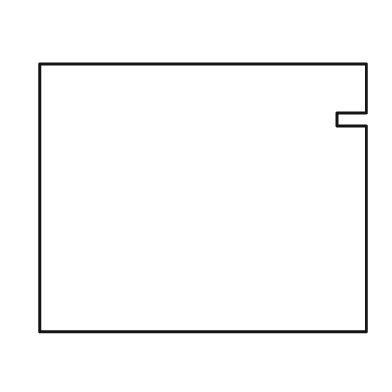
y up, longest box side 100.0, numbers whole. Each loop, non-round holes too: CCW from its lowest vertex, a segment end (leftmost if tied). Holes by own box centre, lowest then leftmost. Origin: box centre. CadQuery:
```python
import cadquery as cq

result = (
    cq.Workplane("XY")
    .moveTo(-50.0, -41.0)
    .lineTo(50.0, -41.0)
    .lineTo(50.0, 22.0)
    .lineTo(41.0, 22.0)
    .lineTo(41.0, 26.0)
    .lineTo(50.0, 26.0)
    .lineTo(50.0, 41.0)
    .lineTo(-50.0, 41.0)
    .close()
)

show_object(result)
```